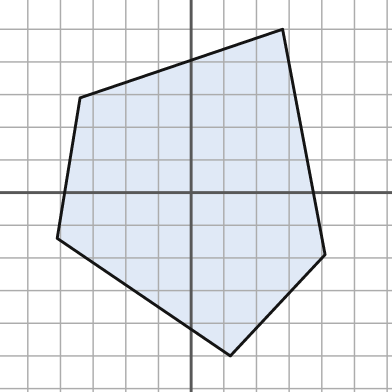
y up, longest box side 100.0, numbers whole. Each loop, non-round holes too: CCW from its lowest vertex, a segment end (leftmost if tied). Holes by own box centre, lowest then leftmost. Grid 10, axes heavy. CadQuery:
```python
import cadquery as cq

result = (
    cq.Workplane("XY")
    .moveTo(12.0, -50.0)
    .lineTo(41.0, -19.0)
    .lineTo(28.0, 50.0)
    .lineTo(-34.0, 29.0)
    .lineTo(-41.0, -14.0)
    .close()
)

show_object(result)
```